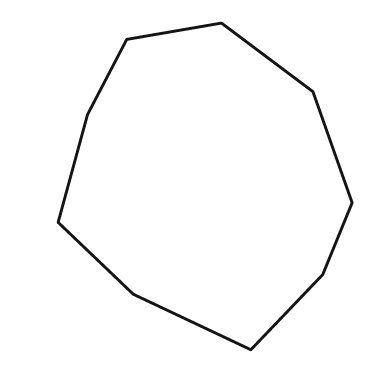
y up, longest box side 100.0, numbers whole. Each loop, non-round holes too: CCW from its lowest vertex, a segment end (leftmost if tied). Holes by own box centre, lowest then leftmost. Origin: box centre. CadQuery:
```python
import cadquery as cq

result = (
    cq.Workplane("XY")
    .moveTo(14.0, -50.0)
    .lineTo(36.0, -27.0)
    .lineTo(45.0, -5.0)
    .lineTo(33.0, 29.0)
    .lineTo(5.0, 50.0)
    .lineTo(-24.0, 45.0)
    .lineTo(-36.0, 22.0)
    .lineTo(-45.0, -11.0)
    .lineTo(-22.0, -33.0)
    .close()
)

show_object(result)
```